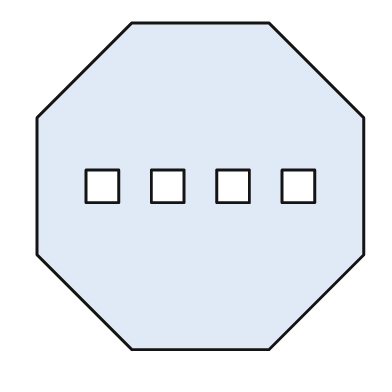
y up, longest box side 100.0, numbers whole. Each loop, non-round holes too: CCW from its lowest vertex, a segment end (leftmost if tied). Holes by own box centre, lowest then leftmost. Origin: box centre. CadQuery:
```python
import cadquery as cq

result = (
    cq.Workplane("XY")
    .moveTo(-21.0, -50.0)
    .lineTo(21.0, -50.0)
    .lineTo(50.0, -21.0)
    .lineTo(50.0, 21.0)
    .lineTo(21.0, 50.0)
    .lineTo(-21.0, 50.0)
    .lineTo(-50.0, 21.0)
    .lineTo(-50.0, -21.0)
    .close()
    .moveTo(-35.0, -5.0)
    .lineTo(-25.0, -5.0)
    .lineTo(-25.0, 5.0)
    .lineTo(-35.0, 5.0)
    .close()
    .moveTo(-15.0, -5.0)
    .lineTo(-5.0, -5.0)
    .lineTo(-5.0, 5.0)
    .lineTo(-15.0, 5.0)
    .close()
    .moveTo(5.0, -5.0)
    .lineTo(15.0, -5.0)
    .lineTo(15.0, 5.0)
    .lineTo(5.0, 5.0)
    .close()
    .moveTo(25.0, -5.0)
    .lineTo(35.0, -5.0)
    .lineTo(35.0, 5.0)
    .lineTo(25.0, 5.0)
    .close()
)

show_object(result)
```